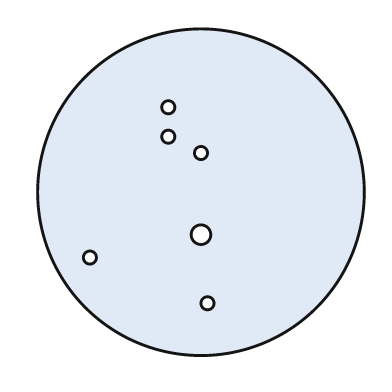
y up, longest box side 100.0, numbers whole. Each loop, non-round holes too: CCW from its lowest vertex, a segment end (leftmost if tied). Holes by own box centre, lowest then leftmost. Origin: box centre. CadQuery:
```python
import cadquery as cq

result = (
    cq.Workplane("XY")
    .moveTo(0.0, 0.0)
    .circle(50.0)
    .moveTo(2.0, -34.0)
    .circle(2.0)
    .moveTo(-34.0, -20.0)
    .circle(2.0)
    .moveTo(0.0, -13.0)
    .circle(3.0)
    .moveTo(0.0, 12.0)
    .circle(2.0)
    .moveTo(-10.0, 17.0)
    .circle(2.0)
    .moveTo(-10.0, 26.0)
    .circle(2.0)
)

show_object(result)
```